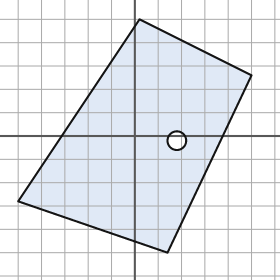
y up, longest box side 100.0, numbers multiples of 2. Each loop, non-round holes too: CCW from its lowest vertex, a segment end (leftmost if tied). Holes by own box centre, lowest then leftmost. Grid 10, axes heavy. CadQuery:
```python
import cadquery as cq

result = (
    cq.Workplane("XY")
    .moveTo(14.0, -50.0)
    .lineTo(50.0, 26.0)
    .lineTo(2.0, 50.0)
    .lineTo(-50.0, -28.0)
    .close()
    .moveTo(18.0, -2.0)
    .circle(4.0)
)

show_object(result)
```